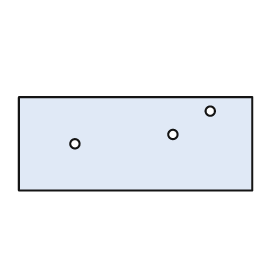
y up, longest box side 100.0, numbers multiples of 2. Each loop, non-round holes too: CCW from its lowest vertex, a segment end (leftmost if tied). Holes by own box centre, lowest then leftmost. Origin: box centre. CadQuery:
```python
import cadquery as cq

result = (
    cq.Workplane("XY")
    .moveTo(-50.0, -20.0)
    .lineTo(50.0, -20.0)
    .lineTo(50.0, 20.0)
    .lineTo(-50.0, 20.0)
    .close()
    .moveTo(-26.0, 0.0)
    .circle(2.0)
    .moveTo(16.0, 4.0)
    .circle(2.0)
    .moveTo(32.0, 14.0)
    .circle(2.0)
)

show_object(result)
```